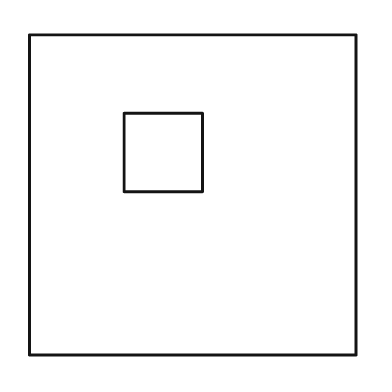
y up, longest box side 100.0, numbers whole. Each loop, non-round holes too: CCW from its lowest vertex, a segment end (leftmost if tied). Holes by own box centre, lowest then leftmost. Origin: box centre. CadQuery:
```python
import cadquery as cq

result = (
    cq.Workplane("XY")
    .moveTo(-50.0, -49.0)
    .lineTo(50.0, -49.0)
    .lineTo(50.0, 49.0)
    .lineTo(-50.0, 49.0)
    .close()
    .moveTo(-21.0, 1.0)
    .lineTo(3.0, 1.0)
    .lineTo(3.0, 25.0)
    .lineTo(-21.0, 25.0)
    .close()
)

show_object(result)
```